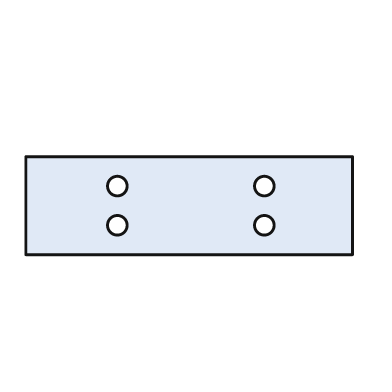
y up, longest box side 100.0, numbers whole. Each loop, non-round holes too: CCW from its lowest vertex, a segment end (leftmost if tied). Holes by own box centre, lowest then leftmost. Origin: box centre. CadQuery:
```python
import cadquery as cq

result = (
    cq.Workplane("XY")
    .moveTo(-50.0, -15.0)
    .lineTo(50.0, -15.0)
    .lineTo(50.0, 15.0)
    .lineTo(-50.0, 15.0)
    .close()
    .moveTo(-22.0, -6.0)
    .circle(3.0)
    .moveTo(23.0, -6.0)
    .circle(3.0)
    .moveTo(-22.0, 6.0)
    .circle(3.0)
    .moveTo(23.0, 6.0)
    .circle(3.0)
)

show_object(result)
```